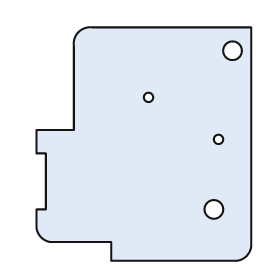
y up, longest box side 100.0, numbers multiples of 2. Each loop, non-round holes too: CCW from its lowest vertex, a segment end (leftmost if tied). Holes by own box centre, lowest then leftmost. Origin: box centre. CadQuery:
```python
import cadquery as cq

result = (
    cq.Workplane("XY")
    .moveTo(-14.0, -50.0)
    .lineTo(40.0, -50.0)
    .threePointArc((44.0, -48.0), (46.0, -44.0))
    .lineTo(46.0, 50.0)
    .lineTo(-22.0, 50.0)
    .threePointArc((-28.0, 48.0), (-30.0, 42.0))
    .lineTo(-30.0, 6.0)
    .lineTo(-46.0, 6.0)
    .lineTo(-46.0, -4.0)
    .lineTo(-42.0, -4.0)
    .lineTo(-42.0, -28.0)
    .lineTo(-46.0, -28.0)
    .lineTo(-46.0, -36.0)
    .threePointArc((-44.0, -40.0), (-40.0, -42.0))
    .lineTo(-14.0, -42.0)
    .close()
    .moveTo(30.0, -28.0)
    .circle(4.0)
    .moveTo(32.0, 2.0)
    .circle(2.0)
    .moveTo(2.0, 20.0)
    .circle(2.0)
    .moveTo(38.0, 40.0)
    .circle(4.0)
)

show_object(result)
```